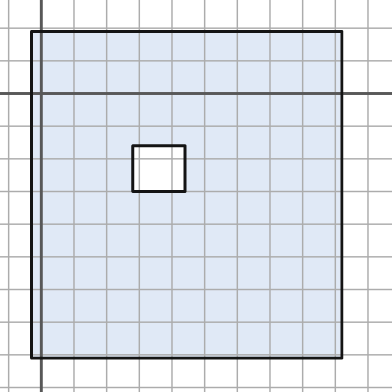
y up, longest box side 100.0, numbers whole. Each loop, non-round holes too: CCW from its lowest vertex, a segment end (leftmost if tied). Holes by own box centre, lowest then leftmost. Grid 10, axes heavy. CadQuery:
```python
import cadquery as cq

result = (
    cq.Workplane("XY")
    .moveTo(-3.0, -81.0)
    .lineTo(92.0, -81.0)
    .lineTo(92.0, 19.0)
    .lineTo(-3.0, 19.0)
    .close()
    .moveTo(28.0, -30.0)
    .lineTo(44.0, -30.0)
    .lineTo(44.0, -16.0)
    .lineTo(28.0, -16.0)
    .close()
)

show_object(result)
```